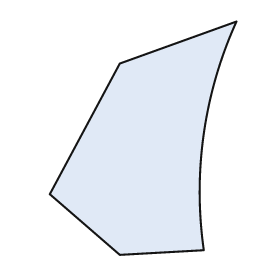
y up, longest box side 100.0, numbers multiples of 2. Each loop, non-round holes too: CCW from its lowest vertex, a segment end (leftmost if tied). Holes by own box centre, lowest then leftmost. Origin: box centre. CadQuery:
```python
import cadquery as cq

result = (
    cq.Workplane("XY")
    .moveTo(-10.0, -50.0)
    .lineTo(26.0, -48.0)
    .threePointArc((26.0, 2.0), (40.0, 50.0))
    .lineTo(-10.0, 32.0)
    .lineTo(-40.0, -24.0)
    .close()
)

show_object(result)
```